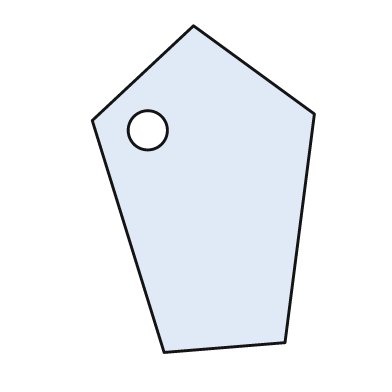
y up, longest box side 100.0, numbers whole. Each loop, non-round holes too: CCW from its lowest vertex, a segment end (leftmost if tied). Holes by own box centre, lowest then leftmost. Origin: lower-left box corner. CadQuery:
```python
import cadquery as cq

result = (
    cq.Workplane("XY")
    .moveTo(22.0, 0.0)
    .lineTo(59.0, 3.0)
    .lineTo(68.0, 73.0)
    .lineTo(31.0, 100.0)
    .lineTo(0.0, 71.0)
    .close()
    .moveTo(17.0, 68.0)
    .circle(6.0)
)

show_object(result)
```